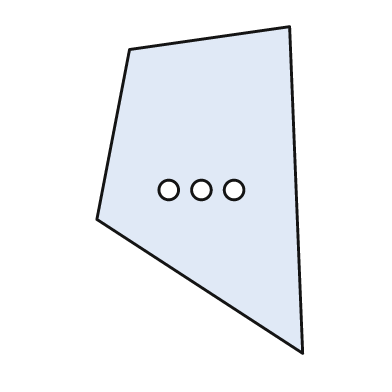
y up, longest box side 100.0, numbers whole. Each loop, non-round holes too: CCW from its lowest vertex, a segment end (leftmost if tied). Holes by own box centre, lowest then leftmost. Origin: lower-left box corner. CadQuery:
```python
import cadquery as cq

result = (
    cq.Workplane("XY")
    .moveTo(63.0, 0.0)
    .lineTo(59.0, 100.0)
    .lineTo(10.0, 93.0)
    .lineTo(0.0, 41.0)
    .close()
    .moveTo(22.0, 50.0)
    .circle(3.0)
    .moveTo(32.0, 50.0)
    .circle(3.0)
    .moveTo(42.0, 50.0)
    .circle(3.0)
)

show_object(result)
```